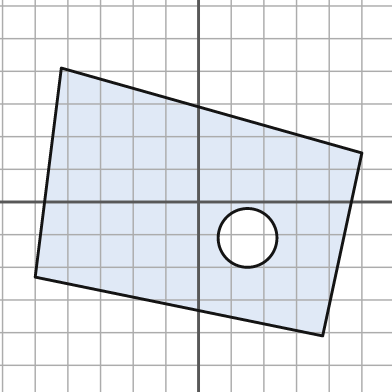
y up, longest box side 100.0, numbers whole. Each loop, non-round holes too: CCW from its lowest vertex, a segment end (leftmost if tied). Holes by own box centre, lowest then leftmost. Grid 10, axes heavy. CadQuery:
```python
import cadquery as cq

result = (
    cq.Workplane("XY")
    .moveTo(38.0, -41.0)
    .lineTo(50.0, 15.0)
    .lineTo(-42.0, 41.0)
    .lineTo(-50.0, -23.0)
    .close()
    .moveTo(15.0, -11.0)
    .circle(9.0)
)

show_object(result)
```